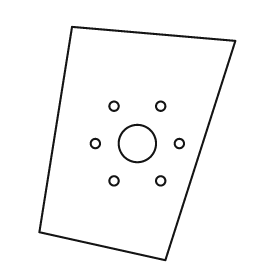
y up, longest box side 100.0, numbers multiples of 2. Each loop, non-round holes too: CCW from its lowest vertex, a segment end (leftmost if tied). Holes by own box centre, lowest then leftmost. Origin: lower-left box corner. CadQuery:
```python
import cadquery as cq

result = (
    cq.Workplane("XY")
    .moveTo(54.0, 0.0)
    .lineTo(84.0, 94.0)
    .lineTo(14.0, 100.0)
    .lineTo(0.0, 12.0)
    .close()
    .moveTo(32.0, 34.0)
    .circle(2.0)
    .moveTo(52.0, 34.0)
    .circle(2.0)
    .moveTo(24.0, 50.0)
    .circle(2.0)
    .moveTo(42.0, 50.0)
    .circle(8.0)
    .moveTo(60.0, 50.0)
    .circle(2.0)
    .moveTo(32.0, 66.0)
    .circle(2.0)
    .moveTo(52.0, 66.0)
    .circle(2.0)
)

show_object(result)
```